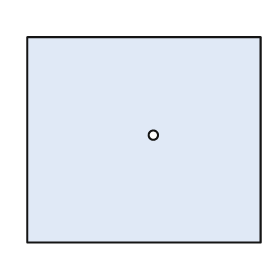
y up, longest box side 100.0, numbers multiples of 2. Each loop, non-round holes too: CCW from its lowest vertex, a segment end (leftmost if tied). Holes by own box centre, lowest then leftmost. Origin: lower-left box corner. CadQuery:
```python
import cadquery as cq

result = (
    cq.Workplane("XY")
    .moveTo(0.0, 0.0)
    .lineTo(100.0, 0.0)
    .lineTo(100.0, 88.0)
    .lineTo(0.0, 88.0)
    .close()
    .moveTo(54.0, 46.0)
    .circle(2.0)
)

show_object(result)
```